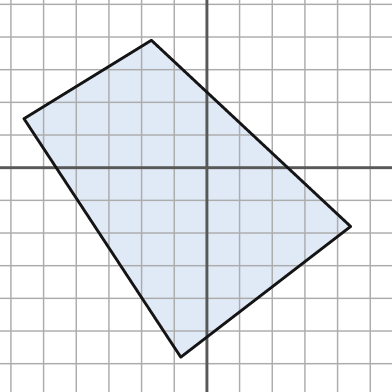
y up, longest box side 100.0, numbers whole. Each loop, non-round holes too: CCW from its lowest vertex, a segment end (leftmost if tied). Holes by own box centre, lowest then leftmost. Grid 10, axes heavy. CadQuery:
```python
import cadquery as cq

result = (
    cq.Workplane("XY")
    .moveTo(-8.0, -58.0)
    .lineTo(44.0, -18.0)
    .lineTo(-17.0, 39.0)
    .lineTo(-56.0, 15.0)
    .close()
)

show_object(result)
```